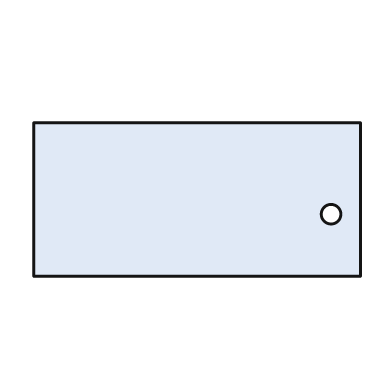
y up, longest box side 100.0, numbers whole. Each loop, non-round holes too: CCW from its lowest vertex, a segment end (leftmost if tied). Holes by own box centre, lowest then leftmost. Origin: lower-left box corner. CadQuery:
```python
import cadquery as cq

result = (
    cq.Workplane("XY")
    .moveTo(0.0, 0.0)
    .lineTo(100.0, 0.0)
    .lineTo(100.0, 47.0)
    .lineTo(0.0, 47.0)
    .close()
    .moveTo(91.0, 19.0)
    .circle(3.0)
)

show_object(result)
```